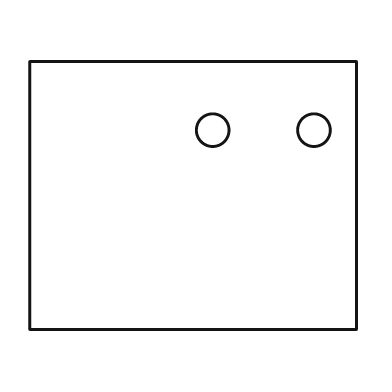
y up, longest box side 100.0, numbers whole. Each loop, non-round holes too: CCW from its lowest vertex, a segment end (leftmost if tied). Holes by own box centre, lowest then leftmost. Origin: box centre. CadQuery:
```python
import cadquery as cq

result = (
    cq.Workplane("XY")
    .moveTo(-50.0, -41.0)
    .lineTo(50.0, -41.0)
    .lineTo(50.0, 41.0)
    .lineTo(-50.0, 41.0)
    .close()
    .moveTo(6.0, 20.0)
    .circle(5.0)
    .moveTo(37.0, 20.0)
    .circle(5.0)
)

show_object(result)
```